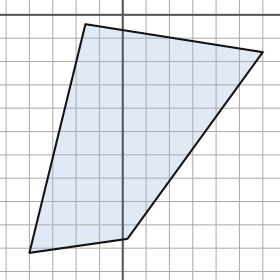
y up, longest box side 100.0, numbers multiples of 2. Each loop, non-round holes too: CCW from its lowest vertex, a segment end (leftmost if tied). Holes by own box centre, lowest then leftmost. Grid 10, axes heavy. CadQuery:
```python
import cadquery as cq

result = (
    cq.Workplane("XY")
    .moveTo(-40.0, -102.0)
    .lineTo(2.0, -96.0)
    .lineTo(60.0, -16.0)
    .lineTo(-16.0, -4.0)
    .close()
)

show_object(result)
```